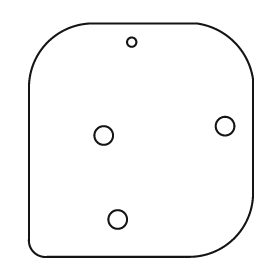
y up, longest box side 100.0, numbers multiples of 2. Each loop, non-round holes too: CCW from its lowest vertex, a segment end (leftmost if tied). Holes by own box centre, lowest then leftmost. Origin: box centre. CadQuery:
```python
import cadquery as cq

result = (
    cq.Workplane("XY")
    .moveTo(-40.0, -50.0)
    .lineTo(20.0, -50.0)
    .threePointArc((40.0, -42.0), (48.0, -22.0))
    .lineTo(48.0, 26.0)
    .threePointArc((40.0, 42.0), (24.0, 50.0))
    .lineTo(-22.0, 50.0)
    .threePointArc((-40.0, 42.0), (-48.0, 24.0))
    .lineTo(-48.0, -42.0)
    .threePointArc((-46.0, -48.0), (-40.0, -50.0))
    .close()
    .moveTo(-10.0, -34.0)
    .circle(4.0)
    .moveTo(-16.0, 2.0)
    .circle(4.0)
    .moveTo(36.0, 6.0)
    .circle(4.0)
    .moveTo(-4.0, 42.0)
    .circle(2.0)
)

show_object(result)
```